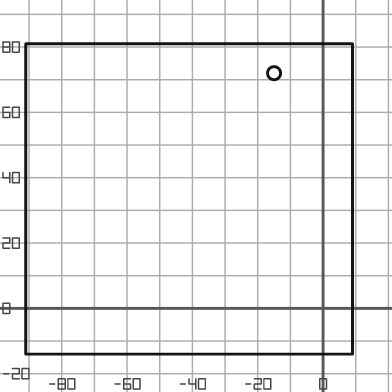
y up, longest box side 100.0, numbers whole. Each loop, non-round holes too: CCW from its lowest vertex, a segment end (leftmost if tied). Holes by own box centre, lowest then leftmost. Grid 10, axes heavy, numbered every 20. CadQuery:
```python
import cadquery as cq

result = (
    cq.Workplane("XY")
    .moveTo(-91.0, -14.0)
    .lineTo(9.0, -14.0)
    .lineTo(9.0, 81.0)
    .lineTo(-91.0, 81.0)
    .close()
    .moveTo(-15.0, 72.0)
    .circle(2.0)
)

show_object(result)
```